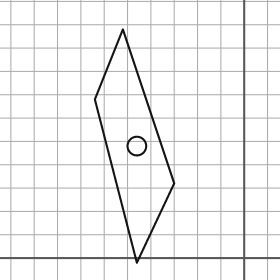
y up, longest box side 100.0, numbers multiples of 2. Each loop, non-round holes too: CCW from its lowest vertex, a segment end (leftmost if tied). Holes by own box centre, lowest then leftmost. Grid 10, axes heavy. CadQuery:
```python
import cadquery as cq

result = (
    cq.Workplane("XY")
    .moveTo(-46.0, -2.0)
    .lineTo(-30.0, 32.0)
    .lineTo(-52.0, 98.0)
    .lineTo(-64.0, 68.0)
    .close()
    .moveTo(-46.0, 48.0)
    .circle(4.0)
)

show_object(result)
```